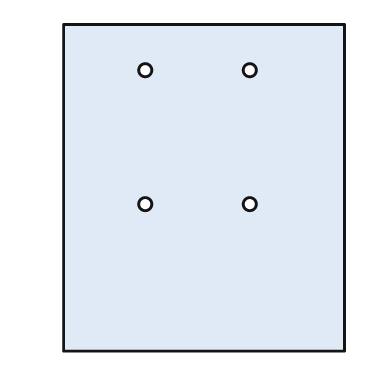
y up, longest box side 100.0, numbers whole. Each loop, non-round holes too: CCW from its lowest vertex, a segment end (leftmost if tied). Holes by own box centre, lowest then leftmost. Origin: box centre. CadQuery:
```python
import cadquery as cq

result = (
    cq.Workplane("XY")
    .moveTo(-43.0, -50.0)
    .lineTo(43.0, -50.0)
    .lineTo(43.0, 50.0)
    .lineTo(-43.0, 50.0)
    .close()
    .moveTo(-18.0, -5.0)
    .circle(2.0)
    .moveTo(14.0, -5.0)
    .circle(2.0)
    .moveTo(-18.0, 36.0)
    .circle(2.0)
    .moveTo(14.0, 36.0)
    .circle(2.0)
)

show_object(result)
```